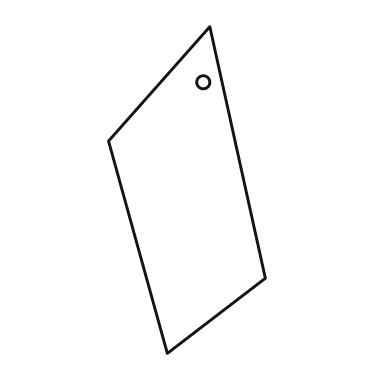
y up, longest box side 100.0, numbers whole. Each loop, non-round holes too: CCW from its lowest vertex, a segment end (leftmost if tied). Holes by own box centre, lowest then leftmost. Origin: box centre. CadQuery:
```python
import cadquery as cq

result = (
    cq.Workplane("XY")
    .moveTo(-6.0, -50.0)
    .lineTo(24.0, -27.0)
    .lineTo(7.0, 50.0)
    .lineTo(-24.0, 15.0)
    .close()
    .moveTo(5.0, 33.0)
    .circle(2.0)
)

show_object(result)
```